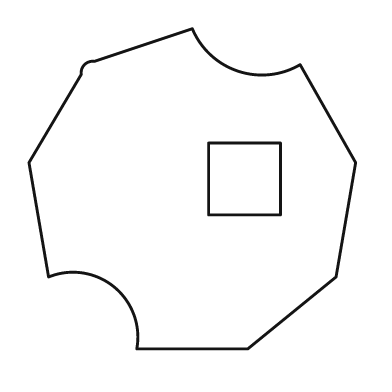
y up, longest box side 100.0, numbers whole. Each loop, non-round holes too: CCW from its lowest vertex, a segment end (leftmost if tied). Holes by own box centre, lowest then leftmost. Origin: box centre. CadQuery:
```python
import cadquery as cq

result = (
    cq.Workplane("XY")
    .moveTo(-17.0, -49.0)
    .lineTo(17.0, -49.0)
    .lineTo(44.0, -27.0)
    .lineTo(50.0, 8.0)
    .lineTo(33.0, 38.0)
    .threePointArc((14.0, 36.0), (0.0, 49.0))
    .lineTo(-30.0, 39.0)
    .threePointArc((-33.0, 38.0), (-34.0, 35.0))
    .lineTo(-50.0, 8.0)
    .lineTo(-44.0, -27.0)
    .threePointArc((-24.0, -30.0), (-17.0, -49.0))
    .close()
    .moveTo(5.0, -8.0)
    .lineTo(27.0, -8.0)
    .lineTo(27.0, 14.0)
    .lineTo(5.0, 14.0)
    .close()
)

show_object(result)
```